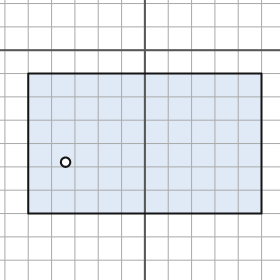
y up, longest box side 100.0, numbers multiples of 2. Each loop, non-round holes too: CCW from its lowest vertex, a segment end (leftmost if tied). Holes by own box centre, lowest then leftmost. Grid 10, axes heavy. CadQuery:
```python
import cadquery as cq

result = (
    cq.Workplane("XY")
    .moveTo(-50.0, -70.0)
    .lineTo(50.0, -70.0)
    .lineTo(50.0, -10.0)
    .lineTo(-50.0, -10.0)
    .close()
    .moveTo(-34.0, -48.0)
    .circle(2.0)
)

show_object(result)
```